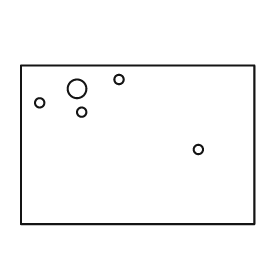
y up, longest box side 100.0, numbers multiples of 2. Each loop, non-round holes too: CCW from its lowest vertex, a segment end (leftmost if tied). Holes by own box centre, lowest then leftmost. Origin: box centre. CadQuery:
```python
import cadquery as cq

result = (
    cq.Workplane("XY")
    .moveTo(-50.0, -34.0)
    .lineTo(50.0, -34.0)
    .lineTo(50.0, 34.0)
    .lineTo(-50.0, 34.0)
    .close()
    .moveTo(26.0, -2.0)
    .circle(2.0)
    .moveTo(-24.0, 14.0)
    .circle(2.0)
    .moveTo(-42.0, 18.0)
    .circle(2.0)
    .moveTo(-26.0, 24.0)
    .circle(4.0)
    .moveTo(-8.0, 28.0)
    .circle(2.0)
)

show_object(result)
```